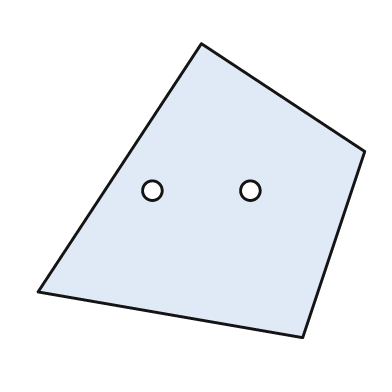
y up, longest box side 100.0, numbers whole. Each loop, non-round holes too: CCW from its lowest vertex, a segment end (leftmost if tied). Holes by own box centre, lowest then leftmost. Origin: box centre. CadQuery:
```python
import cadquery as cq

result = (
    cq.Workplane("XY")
    .moveTo(31.0, -45.0)
    .lineTo(50.0, 12.0)
    .lineTo(0.0, 45.0)
    .lineTo(-50.0, -31.0)
    .close()
    .moveTo(-15.0, 0.0)
    .circle(3.0)
    .moveTo(15.0, 0.0)
    .circle(3.0)
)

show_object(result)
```